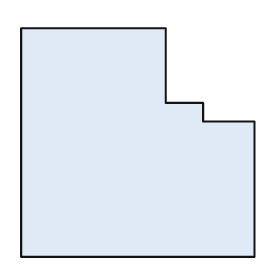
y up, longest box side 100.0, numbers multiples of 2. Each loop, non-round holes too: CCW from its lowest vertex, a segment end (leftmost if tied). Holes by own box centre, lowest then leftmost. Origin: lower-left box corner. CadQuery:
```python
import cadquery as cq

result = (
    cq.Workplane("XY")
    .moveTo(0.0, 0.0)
    .lineTo(100.0, 0.0)
    .lineTo(100.0, 58.0)
    .lineTo(78.0, 58.0)
    .lineTo(78.0, 66.0)
    .lineTo(62.0, 66.0)
    .lineTo(62.0, 98.0)
    .lineTo(0.0, 98.0)
    .close()
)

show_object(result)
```